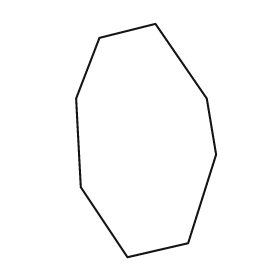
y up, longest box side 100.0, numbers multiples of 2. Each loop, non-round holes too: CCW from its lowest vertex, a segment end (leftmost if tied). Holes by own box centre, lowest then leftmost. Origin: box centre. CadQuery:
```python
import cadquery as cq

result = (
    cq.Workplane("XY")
    .moveTo(-8.0, -50.0)
    .lineTo(18.0, -44.0)
    .lineTo(30.0, -6.0)
    .lineTo(26.0, 18.0)
    .lineTo(4.0, 50.0)
    .lineTo(-20.0, 44.0)
    .lineTo(-30.0, 18.0)
    .lineTo(-28.0, -20.0)
    .close()
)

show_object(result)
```